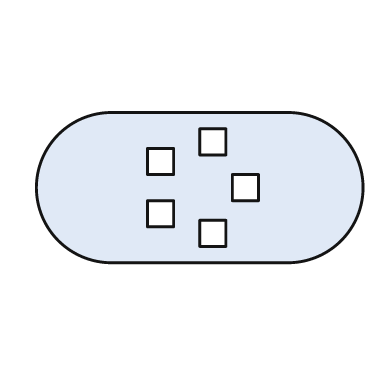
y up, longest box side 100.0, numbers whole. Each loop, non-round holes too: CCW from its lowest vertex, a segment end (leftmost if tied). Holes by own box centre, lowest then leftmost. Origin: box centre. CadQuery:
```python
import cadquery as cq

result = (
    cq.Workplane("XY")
    .moveTo(-27.0, -23.0)
    .lineTo(27.0, -23.0)
    .threePointArc((50.0, 0.0), (27.0, 23.0))
    .lineTo(-27.0, 23.0)
    .threePointArc((-50.0, 0.0), (-27.0, -23.0))
    .close()
    .moveTo(0.0, -18.0)
    .lineTo(8.0, -18.0)
    .lineTo(8.0, -10.0)
    .lineTo(0.0, -10.0)
    .close()
    .moveTo(-16.0, -12.0)
    .lineTo(-8.0, -12.0)
    .lineTo(-8.0, -4.0)
    .lineTo(-16.0, -4.0)
    .close()
    .moveTo(10.0, -4.0)
    .lineTo(18.0, -4.0)
    .lineTo(18.0, 4.0)
    .lineTo(10.0, 4.0)
    .close()
    .moveTo(-16.0, 4.0)
    .lineTo(-8.0, 4.0)
    .lineTo(-8.0, 12.0)
    .lineTo(-16.0, 12.0)
    .close()
    .moveTo(0.0, 10.0)
    .lineTo(8.0, 10.0)
    .lineTo(8.0, 18.0)
    .lineTo(0.0, 18.0)
    .close()
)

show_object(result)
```